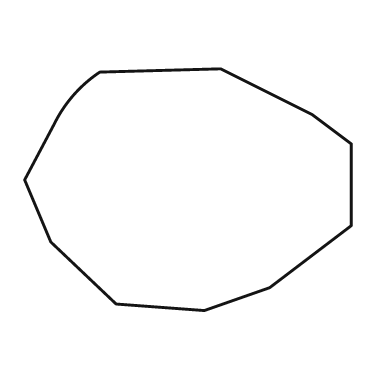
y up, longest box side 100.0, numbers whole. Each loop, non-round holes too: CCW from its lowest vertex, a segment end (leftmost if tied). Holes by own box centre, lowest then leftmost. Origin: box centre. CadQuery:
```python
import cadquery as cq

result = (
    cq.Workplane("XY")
    .moveTo(5.0, -37.0)
    .lineTo(25.0, -30.0)
    .lineTo(50.0, -11.0)
    .lineTo(50.0, 14.0)
    .lineTo(38.0, 23.0)
    .lineTo(10.0, 37.0)
    .lineTo(-27.0, 36.0)
    .threePointArc((-35.0, 29.0), (-41.0, 20.0))
    .lineTo(-50.0, 3.0)
    .lineTo(-42.0, -16.0)
    .lineTo(-22.0, -35.0)
    .close()
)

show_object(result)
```